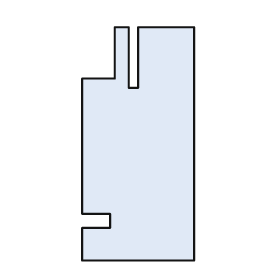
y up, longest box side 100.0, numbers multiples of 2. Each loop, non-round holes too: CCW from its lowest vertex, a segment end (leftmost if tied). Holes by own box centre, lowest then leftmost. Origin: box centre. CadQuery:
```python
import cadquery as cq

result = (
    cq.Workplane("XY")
    .moveTo(-24.0, -50.0)
    .lineTo(24.0, -50.0)
    .lineTo(24.0, 50.0)
    .lineTo(0.0, 50.0)
    .lineTo(0.0, 24.0)
    .lineTo(-4.0, 24.0)
    .lineTo(-4.0, 50.0)
    .lineTo(-10.0, 50.0)
    .lineTo(-10.0, 28.0)
    .lineTo(-24.0, 28.0)
    .lineTo(-24.0, -30.0)
    .lineTo(-12.0, -30.0)
    .lineTo(-12.0, -36.0)
    .lineTo(-24.0, -36.0)
    .close()
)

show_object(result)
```